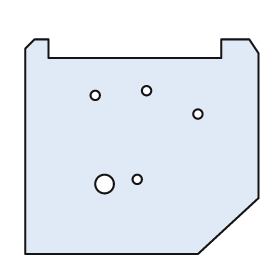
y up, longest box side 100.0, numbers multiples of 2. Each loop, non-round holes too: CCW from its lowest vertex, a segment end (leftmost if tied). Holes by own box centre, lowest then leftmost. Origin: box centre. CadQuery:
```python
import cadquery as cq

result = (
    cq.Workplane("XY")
    .moveTo(-50.0, -46.0)
    .lineTo(24.0, -46.0)
    .lineTo(50.0, -22.0)
    .lineTo(50.0, 40.0)
    .lineTo(46.0, 46.0)
    .lineTo(34.0, 46.0)
    .lineTo(34.0, 38.0)
    .lineTo(-40.0, 38.0)
    .lineTo(-40.0, 46.0)
    .lineTo(-46.0, 46.0)
    .lineTo(-50.0, 42.0)
    .close()
    .moveTo(-16.0, -16.0)
    .circle(4.0)
    .moveTo(-2.0, -14.0)
    .circle(2.0)
    .moveTo(24.0, 14.0)
    .circle(2.0)
    .moveTo(-20.0, 22.0)
    .circle(2.0)
    .moveTo(2.0, 24.0)
    .circle(2.0)
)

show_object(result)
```